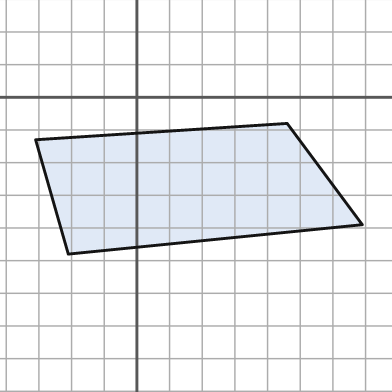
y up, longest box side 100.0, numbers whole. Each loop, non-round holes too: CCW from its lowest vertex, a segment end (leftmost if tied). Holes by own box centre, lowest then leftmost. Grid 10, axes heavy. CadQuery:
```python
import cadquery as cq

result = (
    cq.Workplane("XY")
    .moveTo(-21.0, -48.0)
    .lineTo(69.0, -39.0)
    .lineTo(46.0, -8.0)
    .lineTo(-31.0, -13.0)
    .close()
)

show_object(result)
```